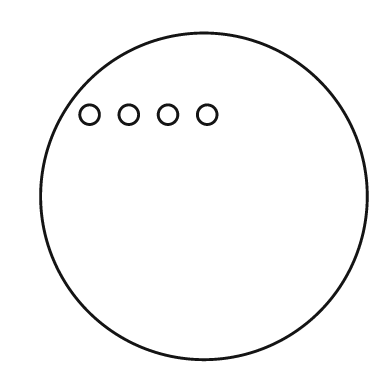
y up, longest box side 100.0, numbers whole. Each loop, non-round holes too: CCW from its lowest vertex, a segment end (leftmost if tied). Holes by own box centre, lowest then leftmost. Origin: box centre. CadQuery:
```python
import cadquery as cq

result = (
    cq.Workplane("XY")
    .moveTo(0.0, 0.0)
    .circle(50.0)
    .moveTo(-35.0, 25.0)
    .circle(3.0)
    .moveTo(-23.0, 25.0)
    .circle(3.0)
    .moveTo(-11.0, 25.0)
    .circle(3.0)
    .moveTo(1.0, 25.0)
    .circle(3.0)
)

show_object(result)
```